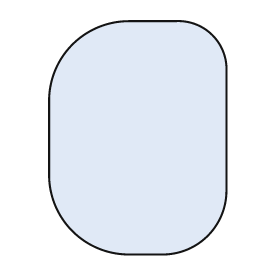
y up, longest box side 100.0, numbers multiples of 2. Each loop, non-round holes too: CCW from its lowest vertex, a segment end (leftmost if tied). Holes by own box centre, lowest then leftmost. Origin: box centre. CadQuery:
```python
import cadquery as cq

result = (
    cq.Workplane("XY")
    .moveTo(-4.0, -50.0)
    .lineTo(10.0, -50.0)
    .threePointArc((30.0, -42.0), (38.0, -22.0))
    .lineTo(38.0, 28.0)
    .threePointArc((32.0, 44.0), (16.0, 50.0))
    .lineTo(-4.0, 50.0)
    .threePointArc((-28.0, 40.0), (-38.0, 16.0))
    .lineTo(-38.0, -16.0)
    .threePointArc((-28.0, -40.0), (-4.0, -50.0))
    .close()
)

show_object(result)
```